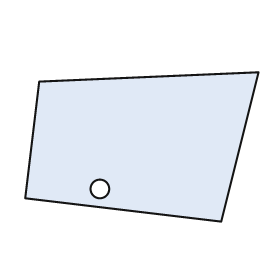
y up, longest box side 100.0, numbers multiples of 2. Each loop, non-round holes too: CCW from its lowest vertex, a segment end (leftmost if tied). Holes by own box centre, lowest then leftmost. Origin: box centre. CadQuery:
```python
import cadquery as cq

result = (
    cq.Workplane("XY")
    .moveTo(34.0, -32.0)
    .lineTo(50.0, 32.0)
    .lineTo(-44.0, 28.0)
    .lineTo(-50.0, -22.0)
    .close()
    .moveTo(-18.0, -18.0)
    .circle(4.0)
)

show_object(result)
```